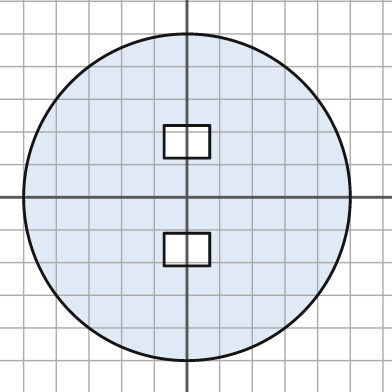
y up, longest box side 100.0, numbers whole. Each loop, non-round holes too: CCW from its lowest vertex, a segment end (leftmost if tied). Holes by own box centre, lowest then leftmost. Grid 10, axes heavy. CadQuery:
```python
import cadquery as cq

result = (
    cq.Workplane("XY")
    .moveTo(0.0, 0.0)
    .circle(50.0)
    .moveTo(-7.0, -21.0)
    .lineTo(7.0, -21.0)
    .lineTo(7.0, -11.0)
    .lineTo(-7.0, -11.0)
    .close()
    .moveTo(-7.0, 12.0)
    .lineTo(7.0, 12.0)
    .lineTo(7.0, 22.0)
    .lineTo(-7.0, 22.0)
    .close()
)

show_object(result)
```